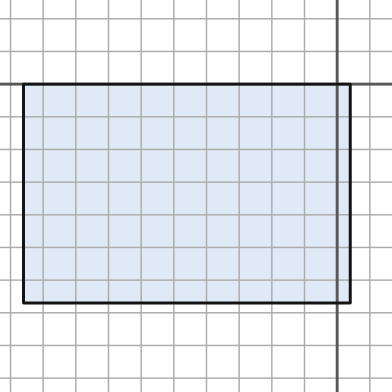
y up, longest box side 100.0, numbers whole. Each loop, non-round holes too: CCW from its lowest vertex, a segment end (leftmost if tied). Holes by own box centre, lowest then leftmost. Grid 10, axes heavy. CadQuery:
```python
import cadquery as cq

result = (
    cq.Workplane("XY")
    .moveTo(-96.0, -67.0)
    .lineTo(4.0, -67.0)
    .lineTo(4.0, 0.0)
    .lineTo(-96.0, 0.0)
    .close()
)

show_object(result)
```